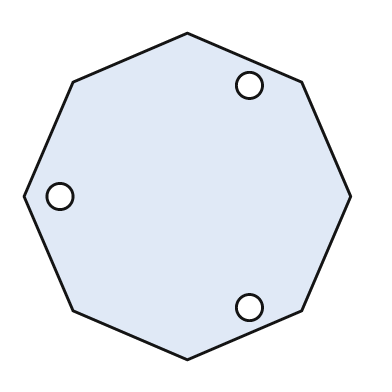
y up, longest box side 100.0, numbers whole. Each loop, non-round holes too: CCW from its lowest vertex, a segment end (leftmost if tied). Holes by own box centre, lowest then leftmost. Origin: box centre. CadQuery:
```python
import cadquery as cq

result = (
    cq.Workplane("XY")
    .moveTo(0.0, -50.0)
    .lineTo(35.0, -35.0)
    .lineTo(50.0, 0.0)
    .lineTo(35.0, 35.0)
    .lineTo(0.0, 50.0)
    .lineTo(-35.0, 35.0)
    .lineTo(-50.0, 0.0)
    .lineTo(-35.0, -35.0)
    .close()
    .moveTo(19.0, -34.0)
    .circle(4.0)
    .moveTo(-39.0, 0.0)
    .circle(4.0)
    .moveTo(19.0, 34.0)
    .circle(4.0)
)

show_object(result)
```